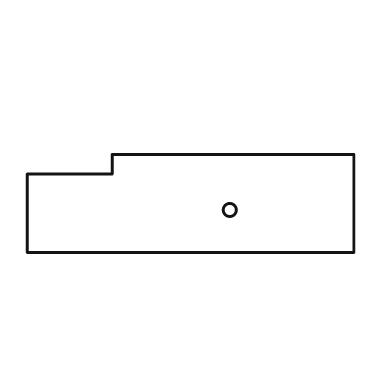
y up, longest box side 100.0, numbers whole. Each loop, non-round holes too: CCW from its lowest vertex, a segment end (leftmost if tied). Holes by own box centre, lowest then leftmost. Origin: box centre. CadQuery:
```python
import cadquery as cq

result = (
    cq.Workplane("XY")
    .moveTo(-50.0, -15.0)
    .lineTo(50.0, -15.0)
    .lineTo(50.0, 15.0)
    .lineTo(-24.0, 15.0)
    .lineTo(-24.0, 9.0)
    .lineTo(-50.0, 9.0)
    .close()
    .moveTo(12.0, -2.0)
    .circle(2.0)
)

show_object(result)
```